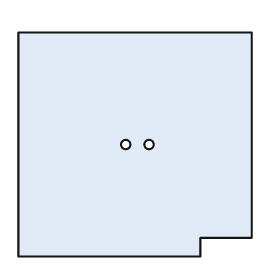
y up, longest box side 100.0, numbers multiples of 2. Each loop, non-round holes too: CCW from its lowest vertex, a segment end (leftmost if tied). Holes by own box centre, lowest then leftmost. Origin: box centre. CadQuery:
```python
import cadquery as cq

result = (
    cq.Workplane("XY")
    .moveTo(-50.0, -48.0)
    .lineTo(28.0, -48.0)
    .lineTo(28.0, -40.0)
    .lineTo(50.0, -40.0)
    .lineTo(50.0, 48.0)
    .lineTo(-50.0, 48.0)
    .close()
    .moveTo(-4.0, 0.0)
    .circle(2.0)
    .moveTo(6.0, 0.0)
    .circle(2.0)
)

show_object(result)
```